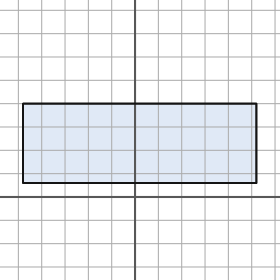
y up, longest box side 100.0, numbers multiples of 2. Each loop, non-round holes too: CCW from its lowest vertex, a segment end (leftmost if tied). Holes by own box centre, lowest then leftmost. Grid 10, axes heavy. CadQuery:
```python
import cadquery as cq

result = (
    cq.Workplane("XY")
    .moveTo(-48.0, 6.0)
    .lineTo(52.0, 6.0)
    .lineTo(52.0, 40.0)
    .lineTo(-48.0, 40.0)
    .close()
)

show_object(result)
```